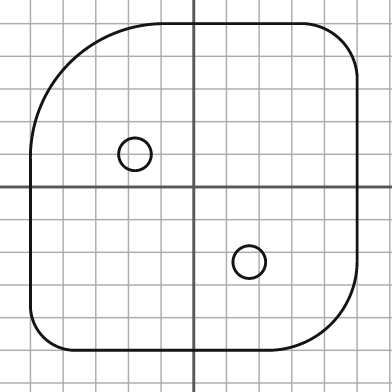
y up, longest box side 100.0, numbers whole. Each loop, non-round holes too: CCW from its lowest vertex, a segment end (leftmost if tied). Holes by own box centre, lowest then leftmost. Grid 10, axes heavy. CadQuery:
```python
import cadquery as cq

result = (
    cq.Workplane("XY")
    .moveTo(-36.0, -50.0)
    .lineTo(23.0, -50.0)
    .threePointArc((42.0, -42.0), (50.0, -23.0))
    .lineTo(50.0, 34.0)
    .threePointArc((45.0, 45.0), (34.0, 50.0))
    .lineTo(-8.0, 50.0)
    .threePointArc((-38.0, 38.0), (-50.0, 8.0))
    .lineTo(-50.0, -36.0)
    .threePointArc((-46.0, -46.0), (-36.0, -50.0))
    .close()
    .moveTo(17.0, -23.0)
    .circle(5.0)
    .moveTo(-18.0, 10.0)
    .circle(5.0)
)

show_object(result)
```